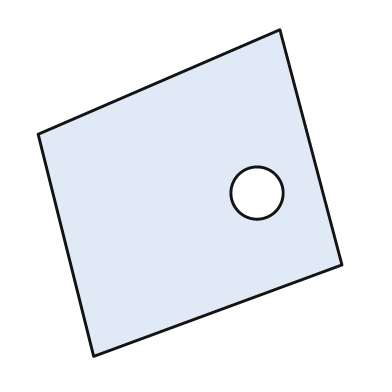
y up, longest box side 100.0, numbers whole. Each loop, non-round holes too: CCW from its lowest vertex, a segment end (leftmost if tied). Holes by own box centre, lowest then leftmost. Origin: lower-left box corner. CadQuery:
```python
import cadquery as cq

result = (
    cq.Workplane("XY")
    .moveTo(17.0, 0.0)
    .lineTo(93.0, 28.0)
    .lineTo(74.0, 100.0)
    .lineTo(0.0, 68.0)
    .close()
    .moveTo(67.0, 50.0)
    .circle(8.0)
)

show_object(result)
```